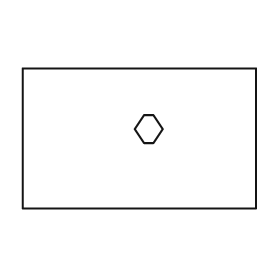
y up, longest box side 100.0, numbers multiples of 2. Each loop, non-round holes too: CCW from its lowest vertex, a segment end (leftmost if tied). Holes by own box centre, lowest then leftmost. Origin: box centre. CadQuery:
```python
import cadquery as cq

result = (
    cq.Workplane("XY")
    .moveTo(-50.0, -30.0)
    .lineTo(50.0, -30.0)
    .lineTo(50.0, 30.0)
    .lineTo(-50.0, 30.0)
    .close()
    .moveTo(2.0, -2.0)
    .lineTo(6.0, -2.0)
    .lineTo(10.0, 4.0)
    .lineTo(6.0, 10.0)
    .lineTo(2.0, 10.0)
    .lineTo(-2.0, 4.0)
    .close()
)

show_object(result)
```